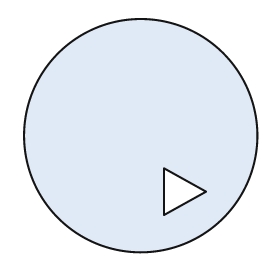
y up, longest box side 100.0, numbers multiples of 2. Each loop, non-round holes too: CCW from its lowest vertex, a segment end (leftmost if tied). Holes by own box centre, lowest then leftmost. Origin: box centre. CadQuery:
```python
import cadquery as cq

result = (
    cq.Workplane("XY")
    .moveTo(0.0, 0.0)
    .circle(50.0)
    .moveTo(10.0, -34.0)
    .lineTo(28.0, -24.0)
    .lineTo(10.0, -14.0)
    .close()
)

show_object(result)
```